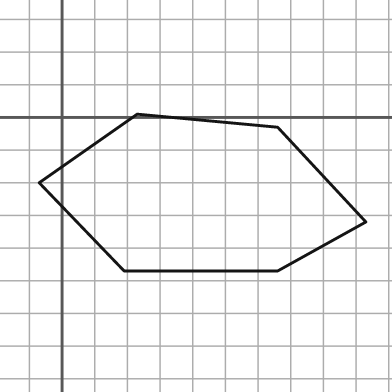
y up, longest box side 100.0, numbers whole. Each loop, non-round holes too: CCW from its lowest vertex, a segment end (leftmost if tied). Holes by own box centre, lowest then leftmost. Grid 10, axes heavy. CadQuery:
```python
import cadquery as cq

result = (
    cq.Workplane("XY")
    .moveTo(19.0, -47.0)
    .lineTo(66.0, -47.0)
    .lineTo(93.0, -32.0)
    .lineTo(66.0, -3.0)
    .lineTo(23.0, 1.0)
    .lineTo(-7.0, -20.0)
    .close()
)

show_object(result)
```